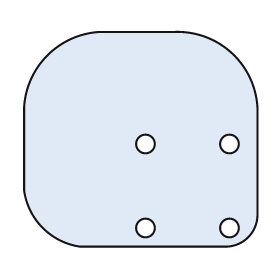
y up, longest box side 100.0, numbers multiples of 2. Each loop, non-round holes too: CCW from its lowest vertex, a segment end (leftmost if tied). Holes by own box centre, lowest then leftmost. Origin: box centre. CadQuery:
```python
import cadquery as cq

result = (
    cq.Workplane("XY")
    .moveTo(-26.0, -46.0)
    .lineTo(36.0, -46.0)
    .threePointArc((46.0, -42.0), (50.0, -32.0))
    .lineTo(50.0, 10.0)
    .threePointArc((40.0, 36.0), (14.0, 46.0))
    .lineTo(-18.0, 46.0)
    .threePointArc((-40.0, 36.0), (-50.0, 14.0))
    .lineTo(-50.0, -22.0)
    .threePointArc((-42.0, -38.0), (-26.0, -46.0))
    .close()
    .moveTo(2.0, -38.0)
    .circle(4.0)
    .moveTo(38.0, -38.0)
    .circle(4.0)
    .moveTo(2.0, -2.0)
    .circle(4.0)
    .moveTo(38.0, -2.0)
    .circle(4.0)
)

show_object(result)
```